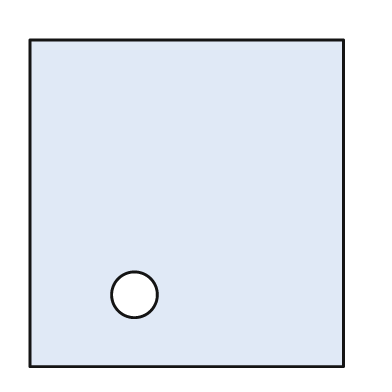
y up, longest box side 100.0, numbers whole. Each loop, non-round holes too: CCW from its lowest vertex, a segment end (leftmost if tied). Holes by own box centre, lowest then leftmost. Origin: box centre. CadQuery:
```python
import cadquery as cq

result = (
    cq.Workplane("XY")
    .moveTo(-48.0, -50.0)
    .lineTo(48.0, -50.0)
    .lineTo(48.0, 50.0)
    .lineTo(-48.0, 50.0)
    .close()
    .moveTo(-16.0, -28.0)
    .circle(7.0)
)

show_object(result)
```